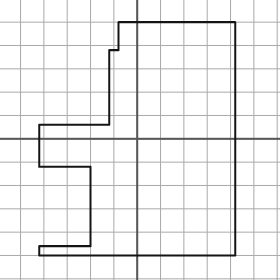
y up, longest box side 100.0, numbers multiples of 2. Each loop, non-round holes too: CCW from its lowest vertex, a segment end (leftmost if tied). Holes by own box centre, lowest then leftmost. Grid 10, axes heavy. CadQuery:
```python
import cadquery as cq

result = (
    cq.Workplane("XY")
    .moveTo(-42.0, -50.0)
    .lineTo(42.0, -50.0)
    .lineTo(42.0, 50.0)
    .lineTo(-8.0, 50.0)
    .lineTo(-8.0, 38.0)
    .lineTo(-12.0, 38.0)
    .lineTo(-12.0, 6.0)
    .lineTo(-42.0, 6.0)
    .lineTo(-42.0, -12.0)
    .lineTo(-20.0, -12.0)
    .lineTo(-20.0, -46.0)
    .lineTo(-42.0, -46.0)
    .close()
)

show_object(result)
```